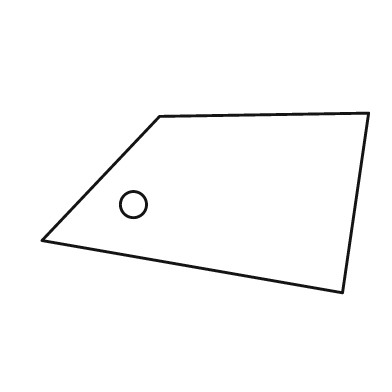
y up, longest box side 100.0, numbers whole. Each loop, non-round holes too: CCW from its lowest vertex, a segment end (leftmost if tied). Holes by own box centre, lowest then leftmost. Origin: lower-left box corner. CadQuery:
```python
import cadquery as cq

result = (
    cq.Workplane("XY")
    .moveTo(92.0, 0.0)
    .lineTo(100.0, 55.0)
    .lineTo(36.0, 54.0)
    .lineTo(0.0, 16.0)
    .close()
    .moveTo(28.0, 27.0)
    .circle(4.0)
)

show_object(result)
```